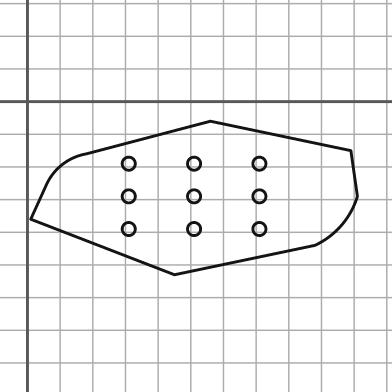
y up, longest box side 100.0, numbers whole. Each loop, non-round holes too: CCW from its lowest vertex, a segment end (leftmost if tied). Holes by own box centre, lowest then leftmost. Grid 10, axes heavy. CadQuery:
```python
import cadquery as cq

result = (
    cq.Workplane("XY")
    .moveTo(45.0, -53.0)
    .lineTo(88.0, -44.0)
    .threePointArc((96.0, -38.0), (101.0, -29.0))
    .lineTo(99.0, -15.0)
    .lineTo(56.0, -6.0)
    .lineTo(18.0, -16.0)
    .threePointArc((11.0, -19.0), (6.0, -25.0))
    .lineTo(1.0, -36.0)
    .close()
    .moveTo(31.0, -39.0)
    .circle(2.0)
    .moveTo(51.0, -39.0)
    .circle(2.0)
    .moveTo(71.0, -39.0)
    .circle(2.0)
    .moveTo(31.0, -29.0)
    .circle(2.0)
    .moveTo(51.0, -29.0)
    .circle(2.0)
    .moveTo(71.0, -29.0)
    .circle(2.0)
    .moveTo(31.0, -19.0)
    .circle(2.0)
    .moveTo(51.0, -19.0)
    .circle(2.0)
    .moveTo(71.0, -19.0)
    .circle(2.0)
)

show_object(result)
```